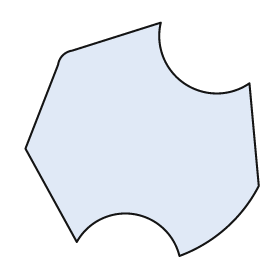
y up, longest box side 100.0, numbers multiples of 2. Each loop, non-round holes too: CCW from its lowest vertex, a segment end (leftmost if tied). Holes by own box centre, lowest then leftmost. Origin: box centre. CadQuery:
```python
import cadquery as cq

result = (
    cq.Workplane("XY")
    .moveTo(16.0, -50.0)
    .threePointArc((36.0, -38.0), (50.0, -20.0))
    .lineTo(46.0, 24.0)
    .threePointArc((18.0, 24.0), (8.0, 50.0))
    .lineTo(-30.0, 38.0)
    .threePointArc((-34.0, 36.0), (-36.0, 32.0))
    .lineTo(-50.0, -4.0)
    .lineTo(-28.0, -44.0)
    .threePointArc((-4.0, -32.0), (16.0, -50.0))
    .close()
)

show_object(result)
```